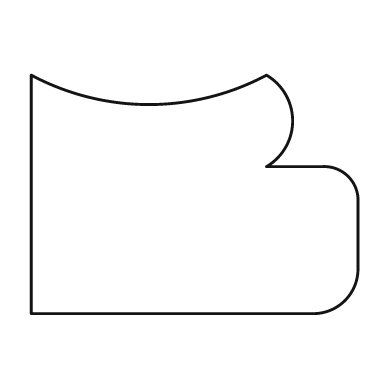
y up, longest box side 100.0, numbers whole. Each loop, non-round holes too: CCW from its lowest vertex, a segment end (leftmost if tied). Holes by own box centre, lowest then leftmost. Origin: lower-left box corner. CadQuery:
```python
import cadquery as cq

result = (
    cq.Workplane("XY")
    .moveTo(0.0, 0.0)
    .lineTo(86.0, 0.0)
    .threePointArc((96.0, 4.0), (100.0, 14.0))
    .lineTo(100.0, 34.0)
    .threePointArc((97.0, 42.0), (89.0, 45.0))
    .lineTo(72.0, 45.0)
    .threePointArc((80.0, 59.0), (72.0, 73.0))
    .threePointArc((36.0, 64.0), (0.0, 73.0))
    .close()
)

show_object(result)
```